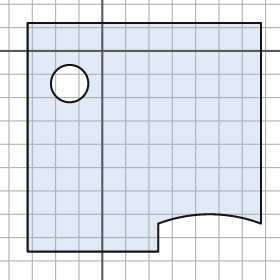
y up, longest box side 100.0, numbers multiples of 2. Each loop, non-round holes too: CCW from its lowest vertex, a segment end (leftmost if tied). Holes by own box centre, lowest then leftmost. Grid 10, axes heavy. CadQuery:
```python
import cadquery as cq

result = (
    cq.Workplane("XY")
    .moveTo(-32.0, -86.0)
    .lineTo(24.0, -86.0)
    .lineTo(24.0, -74.0)
    .threePointArc((46.0, -70.0), (68.0, -74.0))
    .lineTo(68.0, 12.0)
    .lineTo(-32.0, 12.0)
    .close()
    .moveTo(-14.0, -14.0)
    .circle(8.0)
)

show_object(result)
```